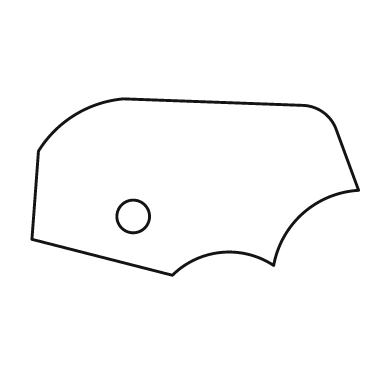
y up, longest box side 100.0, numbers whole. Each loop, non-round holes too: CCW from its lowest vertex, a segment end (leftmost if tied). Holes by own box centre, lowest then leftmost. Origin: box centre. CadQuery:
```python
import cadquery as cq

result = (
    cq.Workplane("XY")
    .moveTo(-7.0, -27.0)
    .threePointArc((8.0, -20.0), (24.0, -24.0))
    .threePointArc((33.0, -8.0), (50.0, -1.0))
    .lineTo(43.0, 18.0)
    .threePointArc((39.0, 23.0), (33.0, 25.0))
    .lineTo(-22.0, 27.0)
    .threePointArc((-37.0, 22.0), (-48.0, 11.0))
    .lineTo(-50.0, -16.0)
    .close()
    .moveTo(-19.0, -9.0)
    .circle(5.0)
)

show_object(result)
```